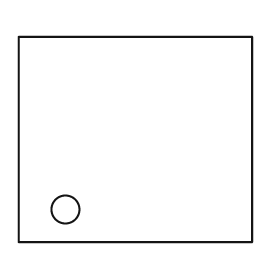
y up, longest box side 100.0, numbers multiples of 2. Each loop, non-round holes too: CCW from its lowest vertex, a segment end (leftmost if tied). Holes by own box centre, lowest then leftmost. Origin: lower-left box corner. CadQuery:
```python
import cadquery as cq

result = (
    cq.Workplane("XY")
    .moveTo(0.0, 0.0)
    .lineTo(100.0, 0.0)
    .lineTo(100.0, 88.0)
    .lineTo(0.0, 88.0)
    .close()
    .moveTo(20.0, 14.0)
    .circle(6.0)
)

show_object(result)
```